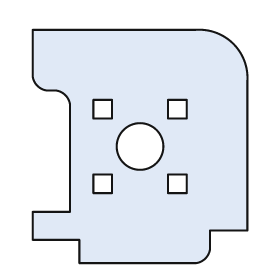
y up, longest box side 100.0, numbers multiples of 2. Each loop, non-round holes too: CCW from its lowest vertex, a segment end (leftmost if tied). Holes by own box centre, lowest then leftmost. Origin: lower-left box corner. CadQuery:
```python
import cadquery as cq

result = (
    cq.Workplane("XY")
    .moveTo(20.0, 0.0)
    .lineTo(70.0, 0.0)
    .threePointArc((74.0, 2.0), (76.0, 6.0))
    .lineTo(76.0, 14.0)
    .lineTo(92.0, 14.0)
    .lineTo(92.0, 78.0)
    .threePointArc((86.0, 94.0), (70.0, 100.0))
    .lineTo(0.0, 100.0)
    .lineTo(0.0, 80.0)
    .threePointArc((2.0, 76.0), (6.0, 74.0))
    .lineTo(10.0, 74.0)
    .threePointArc((14.0, 72.0), (16.0, 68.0))
    .lineTo(16.0, 22.0)
    .lineTo(0.0, 22.0)
    .lineTo(0.0, 10.0)
    .lineTo(20.0, 10.0)
    .close()
    .moveTo(26.0, 30.0)
    .lineTo(34.0, 30.0)
    .lineTo(34.0, 38.0)
    .lineTo(26.0, 38.0)
    .close()
    .moveTo(58.0, 30.0)
    .lineTo(66.0, 30.0)
    .lineTo(66.0, 38.0)
    .lineTo(58.0, 38.0)
    .close()
    .moveTo(46.0, 50.0)
    .circle(10.0)
    .moveTo(26.0, 62.0)
    .lineTo(34.0, 62.0)
    .lineTo(34.0, 70.0)
    .lineTo(26.0, 70.0)
    .close()
    .moveTo(58.0, 62.0)
    .lineTo(66.0, 62.0)
    .lineTo(66.0, 70.0)
    .lineTo(58.0, 70.0)
    .close()
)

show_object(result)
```